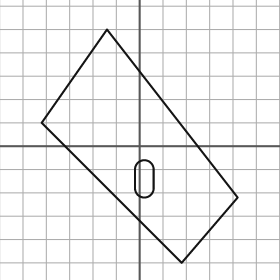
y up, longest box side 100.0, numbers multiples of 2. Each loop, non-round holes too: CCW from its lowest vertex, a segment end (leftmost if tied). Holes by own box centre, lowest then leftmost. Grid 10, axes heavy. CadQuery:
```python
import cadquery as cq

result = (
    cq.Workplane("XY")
    .moveTo(18.0, -50.0)
    .lineTo(42.0, -22.0)
    .lineTo(-14.0, 50.0)
    .lineTo(-42.0, 10.0)
    .close()
    .moveTo(-2.0, -18.0)
    .threePointArc((2.0, -22.0), (6.0, -18.0))
    .lineTo(6.0, -10.0)
    .threePointArc((2.0, -6.0), (-2.0, -10.0))
    .close()
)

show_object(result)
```